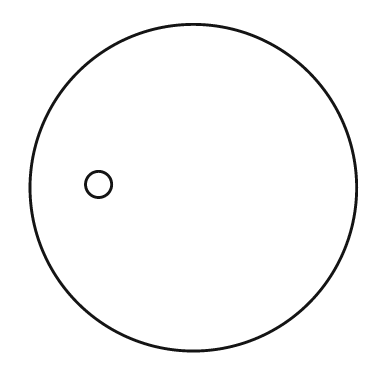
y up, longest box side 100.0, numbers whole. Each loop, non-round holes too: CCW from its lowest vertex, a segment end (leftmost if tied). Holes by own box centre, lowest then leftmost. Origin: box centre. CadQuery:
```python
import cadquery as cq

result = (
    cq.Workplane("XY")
    .moveTo(0.0, 0.0)
    .circle(50.0)
    .moveTo(-29.0, 1.0)
    .circle(4.0)
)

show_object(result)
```